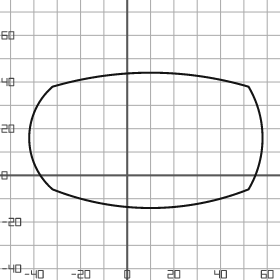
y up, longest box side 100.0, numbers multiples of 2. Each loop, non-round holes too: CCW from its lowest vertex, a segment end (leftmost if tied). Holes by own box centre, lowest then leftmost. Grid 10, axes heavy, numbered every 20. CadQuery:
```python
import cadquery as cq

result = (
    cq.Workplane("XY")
    .moveTo(-32.0, -6.0)
    .threePointArc((10.0, -14.0), (52.0, -6.0))
    .threePointArc((58.0, 16.0), (52.0, 38.0))
    .threePointArc((10.0, 44.0), (-32.0, 38.0))
    .threePointArc((-42.0, 16.0), (-32.0, -6.0))
    .close()
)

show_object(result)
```